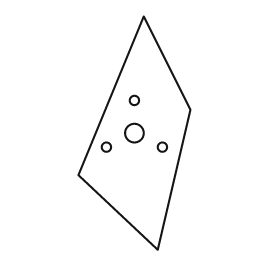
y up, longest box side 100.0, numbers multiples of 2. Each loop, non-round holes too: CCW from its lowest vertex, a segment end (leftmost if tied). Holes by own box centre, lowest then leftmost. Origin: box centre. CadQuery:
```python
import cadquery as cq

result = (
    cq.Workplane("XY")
    .moveTo(10.0, -50.0)
    .lineTo(24.0, 10.0)
    .lineTo(4.0, 50.0)
    .lineTo(-24.0, -18.0)
    .close()
    .moveTo(-12.0, -6.0)
    .circle(2.0)
    .moveTo(12.0, -6.0)
    .circle(2.0)
    .moveTo(0.0, 0.0)
    .circle(4.0)
    .moveTo(0.0, 14.0)
    .circle(2.0)
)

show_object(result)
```